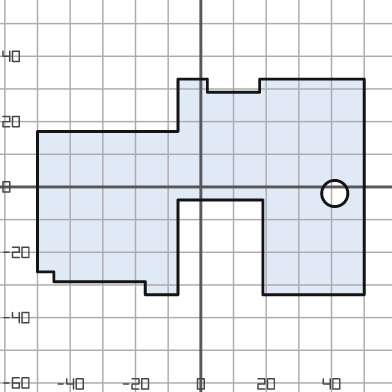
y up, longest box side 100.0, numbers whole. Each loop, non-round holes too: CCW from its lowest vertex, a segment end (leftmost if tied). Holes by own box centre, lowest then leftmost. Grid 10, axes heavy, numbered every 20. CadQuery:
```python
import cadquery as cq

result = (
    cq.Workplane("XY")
    .moveTo(-17.0, -33.0)
    .lineTo(-7.0, -33.0)
    .lineTo(-7.0, -4.0)
    .lineTo(19.0, -4.0)
    .lineTo(19.0, -33.0)
    .lineTo(50.0, -33.0)
    .lineTo(50.0, 33.0)
    .lineTo(18.0, 33.0)
    .lineTo(18.0, 29.0)
    .lineTo(2.0, 29.0)
    .lineTo(2.0, 33.0)
    .lineTo(-7.0, 33.0)
    .lineTo(-7.0, 17.0)
    .lineTo(-50.0, 17.0)
    .lineTo(-50.0, -26.0)
    .lineTo(-45.0, -26.0)
    .lineTo(-45.0, -29.0)
    .lineTo(-17.0, -29.0)
    .close()
    .moveTo(41.0, -2.0)
    .circle(4.0)
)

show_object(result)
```